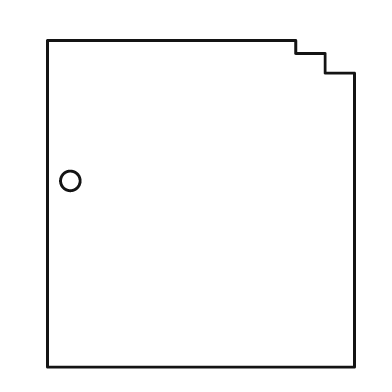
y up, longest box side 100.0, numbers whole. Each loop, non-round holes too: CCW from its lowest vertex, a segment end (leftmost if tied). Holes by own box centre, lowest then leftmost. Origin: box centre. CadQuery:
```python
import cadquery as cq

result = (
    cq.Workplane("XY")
    .moveTo(-47.0, -50.0)
    .lineTo(47.0, -50.0)
    .lineTo(47.0, 40.0)
    .lineTo(38.0, 40.0)
    .lineTo(38.0, 46.0)
    .lineTo(29.0, 46.0)
    .lineTo(29.0, 50.0)
    .lineTo(-47.0, 50.0)
    .close()
    .moveTo(-40.0, 7.0)
    .circle(3.0)
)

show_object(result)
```